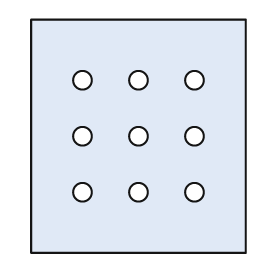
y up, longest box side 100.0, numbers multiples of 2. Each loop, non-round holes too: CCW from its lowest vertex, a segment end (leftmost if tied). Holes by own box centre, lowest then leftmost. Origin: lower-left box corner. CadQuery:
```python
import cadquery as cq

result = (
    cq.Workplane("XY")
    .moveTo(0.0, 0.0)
    .lineTo(92.0, 0.0)
    .lineTo(92.0, 100.0)
    .lineTo(0.0, 100.0)
    .close()
    .moveTo(22.0, 26.0)
    .circle(4.0)
    .moveTo(46.0, 26.0)
    .circle(4.0)
    .moveTo(70.0, 26.0)
    .circle(4.0)
    .moveTo(22.0, 50.0)
    .circle(4.0)
    .moveTo(46.0, 50.0)
    .circle(4.0)
    .moveTo(70.0, 50.0)
    .circle(4.0)
    .moveTo(22.0, 74.0)
    .circle(4.0)
    .moveTo(46.0, 74.0)
    .circle(4.0)
    .moveTo(70.0, 74.0)
    .circle(4.0)
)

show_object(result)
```